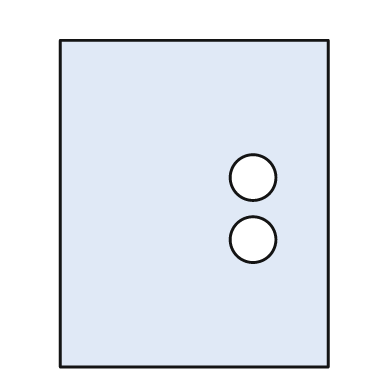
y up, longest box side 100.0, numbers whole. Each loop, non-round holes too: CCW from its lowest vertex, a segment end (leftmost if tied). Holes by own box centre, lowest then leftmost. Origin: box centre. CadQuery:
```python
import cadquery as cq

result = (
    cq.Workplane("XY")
    .moveTo(-41.0, -50.0)
    .lineTo(41.0, -50.0)
    .lineTo(41.0, 50.0)
    .lineTo(-41.0, 50.0)
    .close()
    .moveTo(18.0, -11.0)
    .circle(7.0)
    .moveTo(18.0, 8.0)
    .circle(7.0)
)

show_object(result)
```